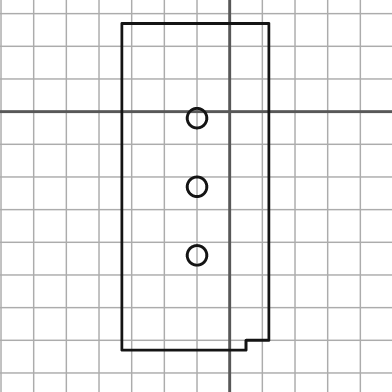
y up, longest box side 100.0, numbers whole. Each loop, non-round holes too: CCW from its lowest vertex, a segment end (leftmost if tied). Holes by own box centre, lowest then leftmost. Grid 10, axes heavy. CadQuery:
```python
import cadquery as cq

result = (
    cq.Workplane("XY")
    .moveTo(-33.0, -73.0)
    .lineTo(5.0, -73.0)
    .lineTo(5.0, -70.0)
    .lineTo(12.0, -70.0)
    .lineTo(12.0, 27.0)
    .lineTo(-33.0, 27.0)
    .close()
    .moveTo(-10.0, -44.0)
    .circle(3.0)
    .moveTo(-10.0, -23.0)
    .circle(3.0)
    .moveTo(-10.0, -2.0)
    .circle(3.0)
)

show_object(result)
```